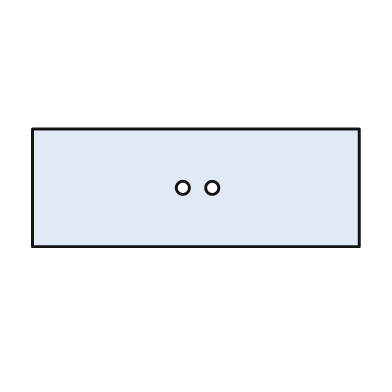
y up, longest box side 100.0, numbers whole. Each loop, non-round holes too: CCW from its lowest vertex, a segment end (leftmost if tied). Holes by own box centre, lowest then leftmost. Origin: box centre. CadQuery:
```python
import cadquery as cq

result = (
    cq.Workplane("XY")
    .moveTo(-50.0, -18.0)
    .lineTo(50.0, -18.0)
    .lineTo(50.0, 18.0)
    .lineTo(-50.0, 18.0)
    .close()
    .moveTo(-4.0, 0.0)
    .circle(2.0)
    .moveTo(5.0, 0.0)
    .circle(2.0)
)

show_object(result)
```